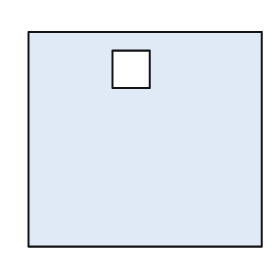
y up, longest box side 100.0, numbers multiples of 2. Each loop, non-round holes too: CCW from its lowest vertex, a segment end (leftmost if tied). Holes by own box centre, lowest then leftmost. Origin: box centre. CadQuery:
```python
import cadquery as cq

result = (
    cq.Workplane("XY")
    .moveTo(-50.0, -46.0)
    .lineTo(50.0, -46.0)
    .lineTo(50.0, 46.0)
    .lineTo(-50.0, 46.0)
    .close()
    .moveTo(-14.0, 22.0)
    .lineTo(2.0, 22.0)
    .lineTo(2.0, 38.0)
    .lineTo(-14.0, 38.0)
    .close()
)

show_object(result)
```